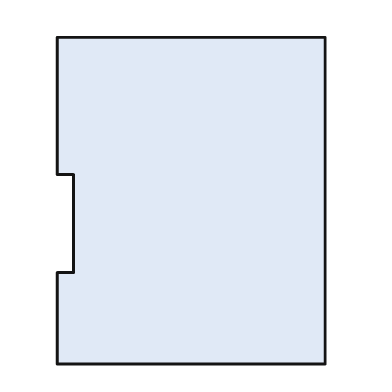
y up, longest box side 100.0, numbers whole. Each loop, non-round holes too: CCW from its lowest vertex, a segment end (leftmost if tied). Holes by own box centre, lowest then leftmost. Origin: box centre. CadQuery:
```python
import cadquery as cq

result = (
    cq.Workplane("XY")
    .moveTo(-41.0, -50.0)
    .lineTo(41.0, -50.0)
    .lineTo(41.0, 50.0)
    .lineTo(-41.0, 50.0)
    .lineTo(-41.0, 8.0)
    .lineTo(-36.0, 8.0)
    .lineTo(-36.0, -22.0)
    .lineTo(-41.0, -22.0)
    .close()
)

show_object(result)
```